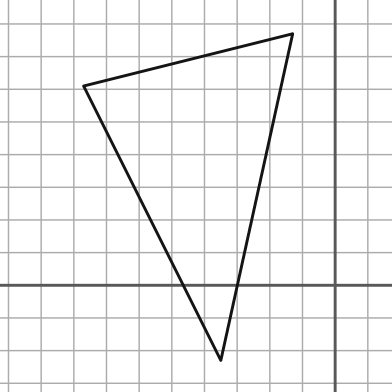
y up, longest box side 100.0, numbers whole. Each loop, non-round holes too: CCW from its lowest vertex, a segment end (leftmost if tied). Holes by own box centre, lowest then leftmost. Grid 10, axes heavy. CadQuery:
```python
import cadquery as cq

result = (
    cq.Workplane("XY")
    .moveTo(-35.0, -23.0)
    .lineTo(-13.0, 77.0)
    .lineTo(-77.0, 61.0)
    .close()
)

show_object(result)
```